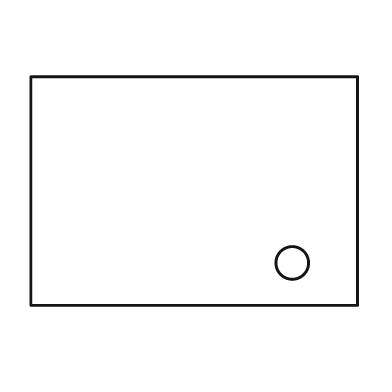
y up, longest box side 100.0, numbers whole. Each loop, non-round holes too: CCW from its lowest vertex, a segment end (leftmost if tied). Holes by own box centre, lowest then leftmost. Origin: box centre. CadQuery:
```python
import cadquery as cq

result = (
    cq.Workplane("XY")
    .moveTo(-50.0, -35.0)
    .lineTo(50.0, -35.0)
    .lineTo(50.0, 35.0)
    .lineTo(-50.0, 35.0)
    .close()
    .moveTo(30.0, -22.0)
    .circle(5.0)
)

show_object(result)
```